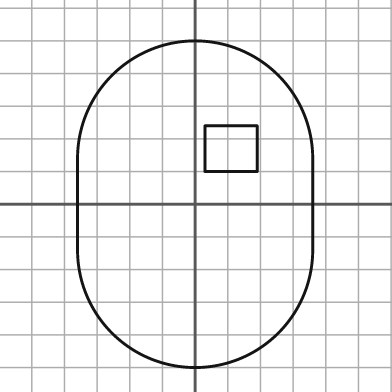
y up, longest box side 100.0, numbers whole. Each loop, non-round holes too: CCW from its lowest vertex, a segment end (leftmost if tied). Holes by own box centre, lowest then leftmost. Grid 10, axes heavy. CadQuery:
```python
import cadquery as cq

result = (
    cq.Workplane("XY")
    .moveTo(-36.0, -14.0)
    .threePointArc((0.0, -50.0), (36.0, -14.0))
    .lineTo(36.0, 14.0)
    .threePointArc((0.0, 50.0), (-36.0, 14.0))
    .close()
    .moveTo(3.0, 10.0)
    .lineTo(19.0, 10.0)
    .lineTo(19.0, 24.0)
    .lineTo(3.0, 24.0)
    .close()
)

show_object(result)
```